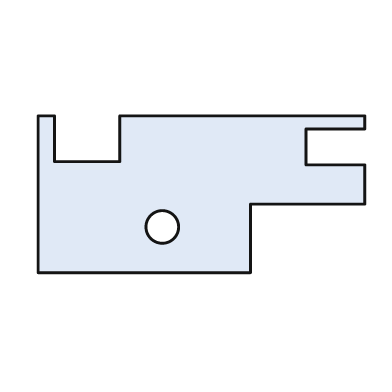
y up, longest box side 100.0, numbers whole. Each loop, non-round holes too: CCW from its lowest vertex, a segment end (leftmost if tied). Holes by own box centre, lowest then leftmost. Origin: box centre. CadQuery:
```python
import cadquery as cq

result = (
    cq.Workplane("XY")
    .moveTo(-50.0, -24.0)
    .lineTo(15.0, -24.0)
    .lineTo(15.0, -3.0)
    .lineTo(50.0, -3.0)
    .lineTo(50.0, 9.0)
    .lineTo(32.0, 9.0)
    .lineTo(32.0, 20.0)
    .lineTo(50.0, 20.0)
    .lineTo(50.0, 24.0)
    .lineTo(-25.0, 24.0)
    .lineTo(-25.0, 10.0)
    .lineTo(-45.0, 10.0)
    .lineTo(-45.0, 24.0)
    .lineTo(-50.0, 24.0)
    .close()
    .moveTo(-12.0, -10.0)
    .circle(5.0)
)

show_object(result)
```